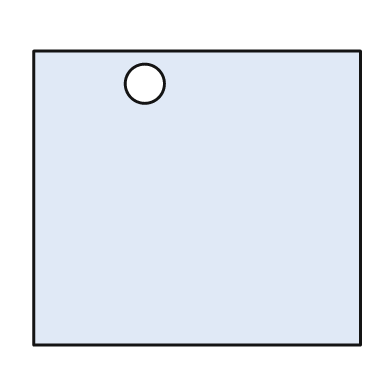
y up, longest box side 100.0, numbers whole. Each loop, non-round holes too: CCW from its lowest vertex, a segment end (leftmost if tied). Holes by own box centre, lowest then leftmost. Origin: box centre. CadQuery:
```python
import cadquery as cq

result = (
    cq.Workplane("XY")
    .moveTo(-50.0, -45.0)
    .lineTo(50.0, -45.0)
    .lineTo(50.0, 45.0)
    .lineTo(-50.0, 45.0)
    .close()
    .moveTo(-16.0, 35.0)
    .circle(6.0)
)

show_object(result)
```